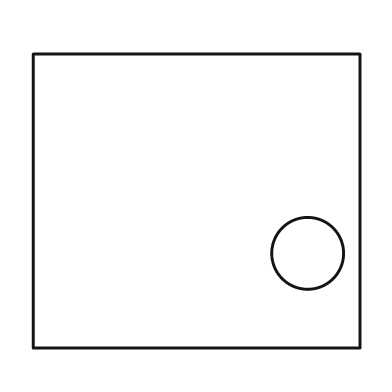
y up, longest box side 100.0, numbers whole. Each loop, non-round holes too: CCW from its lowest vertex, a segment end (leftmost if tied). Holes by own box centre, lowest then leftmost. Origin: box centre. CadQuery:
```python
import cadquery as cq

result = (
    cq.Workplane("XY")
    .moveTo(-50.0, -45.0)
    .lineTo(50.0, -45.0)
    .lineTo(50.0, 45.0)
    .lineTo(-50.0, 45.0)
    .close()
    .moveTo(34.0, -16.0)
    .circle(11.0)
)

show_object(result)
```